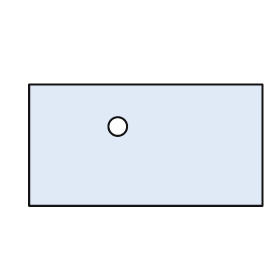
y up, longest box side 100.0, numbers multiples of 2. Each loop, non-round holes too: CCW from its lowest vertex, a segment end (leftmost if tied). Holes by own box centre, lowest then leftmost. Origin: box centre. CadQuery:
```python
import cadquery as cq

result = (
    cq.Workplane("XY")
    .moveTo(-50.0, -26.0)
    .lineTo(50.0, -26.0)
    .lineTo(50.0, 26.0)
    .lineTo(-50.0, 26.0)
    .close()
    .moveTo(-12.0, 8.0)
    .circle(4.0)
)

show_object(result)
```